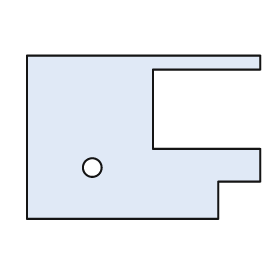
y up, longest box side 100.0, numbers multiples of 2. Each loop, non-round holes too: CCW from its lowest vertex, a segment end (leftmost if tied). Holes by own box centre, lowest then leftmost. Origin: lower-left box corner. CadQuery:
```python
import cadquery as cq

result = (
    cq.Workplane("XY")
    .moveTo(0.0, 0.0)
    .lineTo(82.0, 0.0)
    .lineTo(82.0, 16.0)
    .lineTo(100.0, 16.0)
    .lineTo(100.0, 30.0)
    .lineTo(54.0, 30.0)
    .lineTo(54.0, 64.0)
    .lineTo(100.0, 64.0)
    .lineTo(100.0, 70.0)
    .lineTo(0.0, 70.0)
    .close()
    .moveTo(28.0, 22.0)
    .circle(4.0)
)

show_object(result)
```